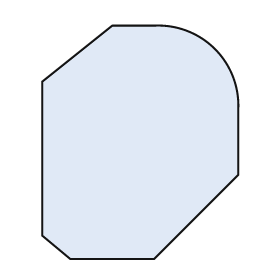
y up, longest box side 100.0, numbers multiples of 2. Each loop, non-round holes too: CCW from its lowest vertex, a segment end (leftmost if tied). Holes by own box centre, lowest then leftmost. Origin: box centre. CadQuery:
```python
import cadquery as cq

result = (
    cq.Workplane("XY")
    .moveTo(-30.0, -50.0)
    .lineTo(6.0, -50.0)
    .lineTo(42.0, -14.0)
    .lineTo(42.0, 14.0)
    .threePointArc((32.0, 40.0), (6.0, 50.0))
    .lineTo(-12.0, 50.0)
    .lineTo(-42.0, 26.0)
    .lineTo(-42.0, -40.0)
    .close()
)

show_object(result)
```